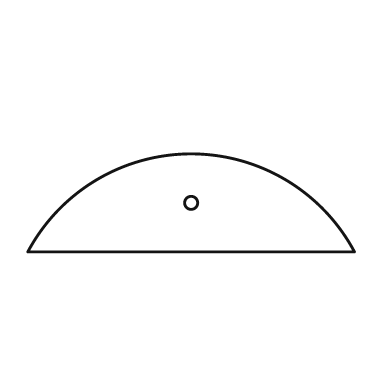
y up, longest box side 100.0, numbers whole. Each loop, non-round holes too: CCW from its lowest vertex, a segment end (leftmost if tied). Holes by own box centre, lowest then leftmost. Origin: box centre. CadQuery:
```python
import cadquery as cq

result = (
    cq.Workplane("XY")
    .moveTo(-50.0, -15.0)
    .lineTo(50.0, -15.0)
    .threePointArc((0.0, 15.0), (-50.0, -15.0))
    .close()
    .moveTo(0.0, 0.0)
    .circle(2.0)
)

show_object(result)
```